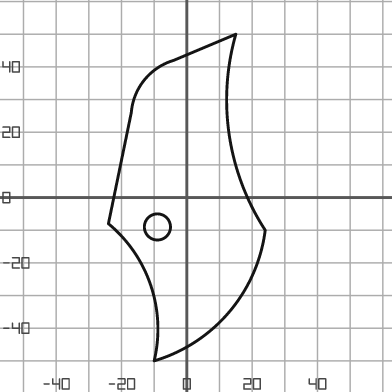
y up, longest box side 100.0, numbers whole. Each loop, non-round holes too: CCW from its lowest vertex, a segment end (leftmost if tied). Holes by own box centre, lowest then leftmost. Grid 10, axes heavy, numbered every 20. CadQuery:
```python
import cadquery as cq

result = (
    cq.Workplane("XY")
    .moveTo(-10.0, -50.0)
    .threePointArc((13.0, -35.0), (24.0, -10.0))
    .threePointArc((13.0, 19.0), (15.0, 50.0))
    .lineTo(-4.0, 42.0)
    .threePointArc((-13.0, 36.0), (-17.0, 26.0))
    .lineTo(-24.0, -8.0)
    .threePointArc((-11.0, -27.0), (-10.0, -50.0))
    .close()
    .moveTo(-9.0, -9.0)
    .circle(4.0)
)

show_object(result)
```